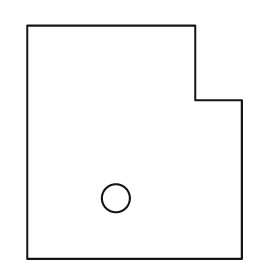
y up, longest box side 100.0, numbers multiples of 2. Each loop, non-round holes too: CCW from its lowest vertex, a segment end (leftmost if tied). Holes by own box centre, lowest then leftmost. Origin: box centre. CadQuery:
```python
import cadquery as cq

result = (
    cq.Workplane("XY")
    .moveTo(-46.0, -50.0)
    .lineTo(46.0, -50.0)
    .lineTo(46.0, 18.0)
    .lineTo(26.0, 18.0)
    .lineTo(26.0, 50.0)
    .lineTo(-46.0, 50.0)
    .close()
    .moveTo(-8.0, -24.0)
    .circle(6.0)
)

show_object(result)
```